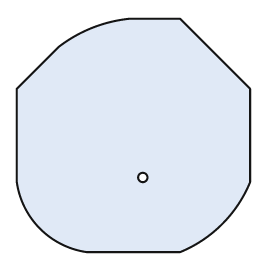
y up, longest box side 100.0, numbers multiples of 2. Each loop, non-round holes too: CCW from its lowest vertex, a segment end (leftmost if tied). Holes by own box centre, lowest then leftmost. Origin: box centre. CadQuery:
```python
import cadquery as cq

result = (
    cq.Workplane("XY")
    .moveTo(-20.0, -50.0)
    .lineTo(20.0, -50.0)
    .threePointArc((38.0, -38.0), (50.0, -20.0))
    .lineTo(50.0, 20.0)
    .lineTo(20.0, 50.0)
    .lineTo(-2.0, 50.0)
    .threePointArc((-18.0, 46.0), (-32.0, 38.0))
    .lineTo(-50.0, 20.0)
    .lineTo(-50.0, -20.0)
    .threePointArc((-40.0, -40.0), (-20.0, -50.0))
    .close()
    .moveTo(4.0, -18.0)
    .circle(2.0)
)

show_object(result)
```